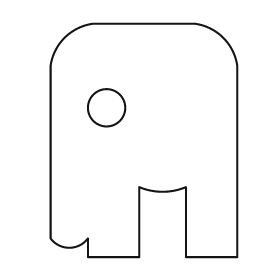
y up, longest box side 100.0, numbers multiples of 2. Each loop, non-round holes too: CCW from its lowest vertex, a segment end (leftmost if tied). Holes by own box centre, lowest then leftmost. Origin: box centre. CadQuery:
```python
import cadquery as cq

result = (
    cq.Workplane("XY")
    .moveTo(-24.0, -50.0)
    .lineTo(-2.0, -50.0)
    .lineTo(-2.0, -20.0)
    .threePointArc((8.0, -22.0), (18.0, -20.0))
    .lineTo(18.0, -50.0)
    .lineTo(40.0, -50.0)
    .lineTo(40.0, 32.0)
    .threePointArc((34.0, 44.0), (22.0, 50.0))
    .lineTo(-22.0, 50.0)
    .threePointArc((-34.0, 44.0), (-40.0, 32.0))
    .lineTo(-40.0, -42.0)
    .threePointArc((-32.0, -46.0), (-24.0, -42.0))
    .close()
    .moveTo(-16.0, 14.0)
    .circle(8.0)
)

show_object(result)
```